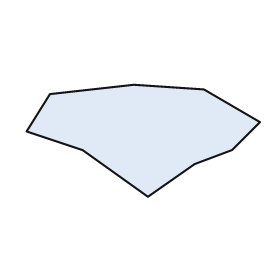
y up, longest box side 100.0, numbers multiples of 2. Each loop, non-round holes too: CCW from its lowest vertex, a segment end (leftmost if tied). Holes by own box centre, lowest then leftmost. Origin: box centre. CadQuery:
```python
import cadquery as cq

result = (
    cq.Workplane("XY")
    .moveTo(2.0, -24.0)
    .lineTo(22.0, -10.0)
    .lineTo(38.0, -4.0)
    .lineTo(50.0, 8.0)
    .lineTo(26.0, 22.0)
    .lineTo(-4.0, 24.0)
    .lineTo(-40.0, 20.0)
    .lineTo(-50.0, 4.0)
    .lineTo(-26.0, -4.0)
    .close()
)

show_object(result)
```